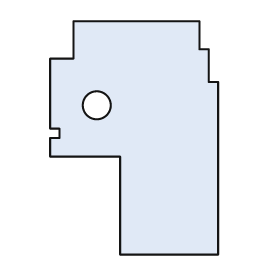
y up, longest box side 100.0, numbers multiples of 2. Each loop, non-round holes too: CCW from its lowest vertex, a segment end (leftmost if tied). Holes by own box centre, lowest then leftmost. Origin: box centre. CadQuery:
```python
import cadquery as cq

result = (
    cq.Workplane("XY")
    .moveTo(-6.0, -50.0)
    .lineTo(36.0, -50.0)
    .lineTo(36.0, 24.0)
    .lineTo(32.0, 24.0)
    .lineTo(32.0, 38.0)
    .lineTo(28.0, 38.0)
    .lineTo(28.0, 50.0)
    .lineTo(-26.0, 50.0)
    .lineTo(-26.0, 34.0)
    .lineTo(-36.0, 34.0)
    .lineTo(-36.0, 4.0)
    .lineTo(-32.0, 4.0)
    .lineTo(-32.0, 0.0)
    .lineTo(-36.0, 0.0)
    .lineTo(-36.0, -8.0)
    .lineTo(-6.0, -8.0)
    .close()
    .moveTo(-16.0, 14.0)
    .circle(6.0)
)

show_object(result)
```